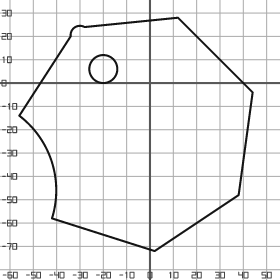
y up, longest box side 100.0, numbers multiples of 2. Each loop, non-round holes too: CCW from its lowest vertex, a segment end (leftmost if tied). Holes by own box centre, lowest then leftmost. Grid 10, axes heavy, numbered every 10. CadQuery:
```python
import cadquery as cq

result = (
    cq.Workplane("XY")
    .moveTo(2.0, -72.0)
    .lineTo(38.0, -48.0)
    .lineTo(44.0, -4.0)
    .lineTo(12.0, 28.0)
    .lineTo(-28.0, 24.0)
    .threePointArc((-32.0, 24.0), (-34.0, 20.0))
    .lineTo(-56.0, -14.0)
    .threePointArc((-42.0, -34.0), (-42.0, -58.0))
    .close()
    .moveTo(-20.0, 6.0)
    .circle(6.0)
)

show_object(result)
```